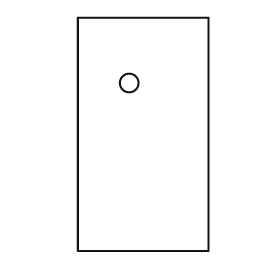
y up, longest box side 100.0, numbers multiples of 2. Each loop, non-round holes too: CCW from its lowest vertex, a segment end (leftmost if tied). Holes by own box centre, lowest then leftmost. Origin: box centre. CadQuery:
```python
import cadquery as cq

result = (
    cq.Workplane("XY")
    .moveTo(-28.0, -50.0)
    .lineTo(28.0, -50.0)
    .lineTo(28.0, 50.0)
    .lineTo(-28.0, 50.0)
    .close()
    .moveTo(-6.0, 22.0)
    .circle(4.0)
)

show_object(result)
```